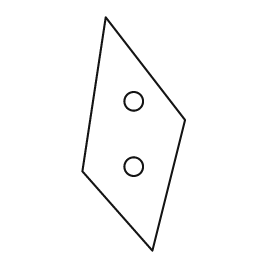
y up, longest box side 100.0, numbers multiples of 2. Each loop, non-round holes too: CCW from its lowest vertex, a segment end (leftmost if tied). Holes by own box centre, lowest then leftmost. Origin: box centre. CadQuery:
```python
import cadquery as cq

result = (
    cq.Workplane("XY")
    .moveTo(8.0, -50.0)
    .lineTo(22.0, 6.0)
    .lineTo(-12.0, 50.0)
    .lineTo(-22.0, -16.0)
    .close()
    .moveTo(0.0, -14.0)
    .circle(4.0)
    .moveTo(0.0, 14.0)
    .circle(4.0)
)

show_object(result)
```